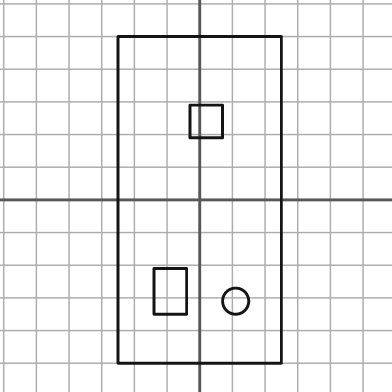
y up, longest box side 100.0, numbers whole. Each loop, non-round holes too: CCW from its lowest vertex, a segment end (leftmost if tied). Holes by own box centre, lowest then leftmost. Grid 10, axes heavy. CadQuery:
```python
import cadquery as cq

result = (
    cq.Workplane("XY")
    .moveTo(-25.0, -50.0)
    .lineTo(25.0, -50.0)
    .lineTo(25.0, 50.0)
    .lineTo(-25.0, 50.0)
    .close()
    .moveTo(11.0, -31.0)
    .circle(4.0)
    .moveTo(-14.0, -35.0)
    .lineTo(-4.0, -35.0)
    .lineTo(-4.0, -21.0)
    .lineTo(-14.0, -21.0)
    .close()
    .moveTo(-3.0, 19.0)
    .lineTo(7.0, 19.0)
    .lineTo(7.0, 29.0)
    .lineTo(-3.0, 29.0)
    .close()
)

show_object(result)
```